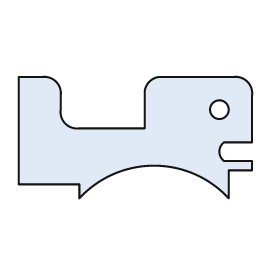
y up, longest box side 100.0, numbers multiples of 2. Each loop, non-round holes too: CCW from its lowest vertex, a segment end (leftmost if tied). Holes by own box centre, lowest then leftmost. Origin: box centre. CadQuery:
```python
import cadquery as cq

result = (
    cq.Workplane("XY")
    .moveTo(-24.0, -26.0)
    .threePointArc((8.0, -12.0), (40.0, -26.0))
    .lineTo(40.0, -14.0)
    .lineTo(50.0, -14.0)
    .lineTo(50.0, -10.0)
    .lineTo(38.0, -10.0)
    .threePointArc((36.0, -6.0), (38.0, -2.0))
    .lineTo(50.0, -2.0)
    .lineTo(50.0, 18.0)
    .threePointArc((48.0, 24.0), (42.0, 26.0))
    .lineTo(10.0, 26.0)
    .threePointArc((6.0, 24.0), (4.0, 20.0))
    .lineTo(4.0, 4.0)
    .lineTo(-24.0, 4.0)
    .threePointArc((-30.0, 6.0), (-32.0, 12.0))
    .lineTo(-32.0, 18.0)
    .threePointArc((-34.0, 24.0), (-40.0, 26.0))
    .lineTo(-50.0, 26.0)
    .lineTo(-50.0, -20.0)
    .lineTo(-24.0, -20.0)
    .close()
    .moveTo(36.0, 12.0)
    .circle(4.0)
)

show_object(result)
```